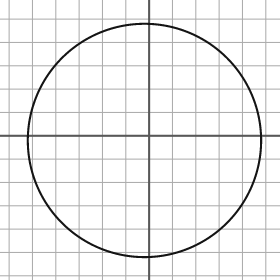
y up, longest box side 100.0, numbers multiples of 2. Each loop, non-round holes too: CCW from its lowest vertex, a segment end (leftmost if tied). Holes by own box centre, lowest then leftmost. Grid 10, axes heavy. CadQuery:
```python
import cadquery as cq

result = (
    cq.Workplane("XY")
    .moveTo(-2.0, -2.0)
    .circle(50.0)
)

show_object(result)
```